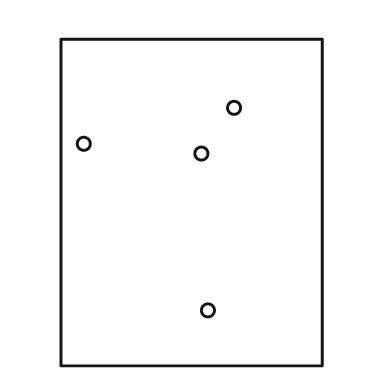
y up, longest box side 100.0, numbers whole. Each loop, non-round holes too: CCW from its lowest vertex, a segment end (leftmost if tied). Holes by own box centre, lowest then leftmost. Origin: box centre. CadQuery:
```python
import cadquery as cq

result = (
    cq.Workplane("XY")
    .moveTo(-40.0, -50.0)
    .lineTo(40.0, -50.0)
    .lineTo(40.0, 50.0)
    .lineTo(-40.0, 50.0)
    .close()
    .moveTo(5.0, -33.0)
    .circle(2.0)
    .moveTo(3.0, 15.0)
    .circle(2.0)
    .moveTo(-33.0, 18.0)
    .circle(2.0)
    .moveTo(13.0, 29.0)
    .circle(2.0)
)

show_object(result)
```